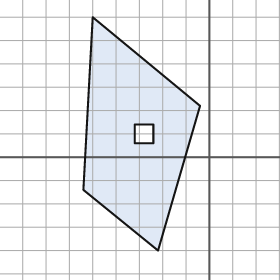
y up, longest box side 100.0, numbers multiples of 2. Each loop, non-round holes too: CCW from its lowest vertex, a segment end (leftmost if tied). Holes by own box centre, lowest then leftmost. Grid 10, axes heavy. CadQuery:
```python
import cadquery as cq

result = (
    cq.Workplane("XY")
    .moveTo(-22.0, -40.0)
    .lineTo(-4.0, 22.0)
    .lineTo(-50.0, 60.0)
    .lineTo(-54.0, -14.0)
    .close()
    .moveTo(-32.0, 6.0)
    .lineTo(-24.0, 6.0)
    .lineTo(-24.0, 14.0)
    .lineTo(-32.0, 14.0)
    .close()
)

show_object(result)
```